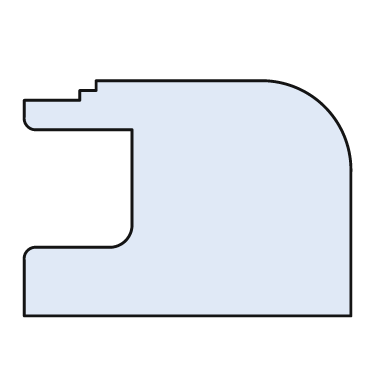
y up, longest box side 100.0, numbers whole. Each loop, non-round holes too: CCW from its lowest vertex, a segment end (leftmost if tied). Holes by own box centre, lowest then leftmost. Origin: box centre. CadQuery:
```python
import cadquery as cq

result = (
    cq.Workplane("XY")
    .moveTo(-50.0, -36.0)
    .lineTo(50.0, -36.0)
    .lineTo(50.0, 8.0)
    .threePointArc((42.0, 28.0), (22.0, 36.0))
    .lineTo(-28.0, 36.0)
    .lineTo(-28.0, 33.0)
    .lineTo(-33.0, 33.0)
    .lineTo(-33.0, 30.0)
    .lineTo(-50.0, 30.0)
    .lineTo(-50.0, 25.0)
    .threePointArc((-49.0, 22.0), (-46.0, 21.0))
    .lineTo(-17.0, 21.0)
    .lineTo(-17.0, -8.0)
    .threePointArc((-19.0, -13.0), (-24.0, -15.0))
    .lineTo(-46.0, -15.0)
    .threePointArc((-49.0, -16.0), (-50.0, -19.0))
    .close()
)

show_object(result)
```